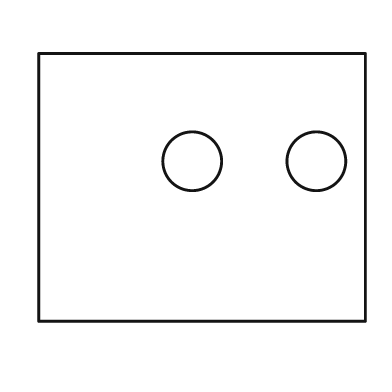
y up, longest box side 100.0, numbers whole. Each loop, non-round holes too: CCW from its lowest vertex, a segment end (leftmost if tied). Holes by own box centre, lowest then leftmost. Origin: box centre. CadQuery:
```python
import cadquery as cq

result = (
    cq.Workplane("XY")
    .moveTo(-50.0, -41.0)
    .lineTo(50.0, -41.0)
    .lineTo(50.0, 41.0)
    .lineTo(-50.0, 41.0)
    .close()
    .moveTo(-3.0, 8.0)
    .circle(9.0)
    .moveTo(35.0, 8.0)
    .circle(9.0)
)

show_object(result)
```